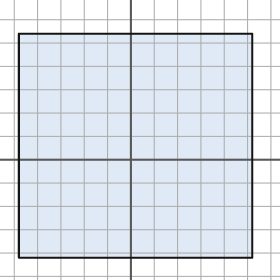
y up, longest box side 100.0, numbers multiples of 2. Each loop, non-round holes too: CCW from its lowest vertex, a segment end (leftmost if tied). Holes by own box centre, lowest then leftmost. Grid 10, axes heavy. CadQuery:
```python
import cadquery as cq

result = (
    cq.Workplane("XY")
    .moveTo(-48.0, -42.0)
    .lineTo(52.0, -42.0)
    .lineTo(52.0, 54.0)
    .lineTo(-48.0, 54.0)
    .close()
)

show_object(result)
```